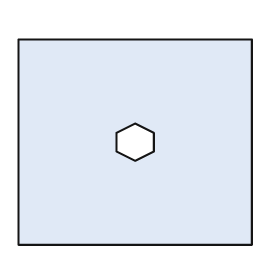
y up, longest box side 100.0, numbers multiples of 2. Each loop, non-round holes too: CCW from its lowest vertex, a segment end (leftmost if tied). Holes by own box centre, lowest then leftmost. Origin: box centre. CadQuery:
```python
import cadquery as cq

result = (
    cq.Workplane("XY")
    .moveTo(-50.0, -44.0)
    .lineTo(50.0, -44.0)
    .lineTo(50.0, 44.0)
    .lineTo(-50.0, 44.0)
    .close()
    .moveTo(0.0, -8.0)
    .lineTo(8.0, -4.0)
    .lineTo(8.0, 4.0)
    .lineTo(0.0, 8.0)
    .lineTo(-8.0, 4.0)
    .lineTo(-8.0, -4.0)
    .close()
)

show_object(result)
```